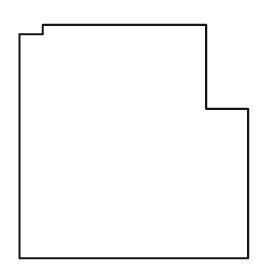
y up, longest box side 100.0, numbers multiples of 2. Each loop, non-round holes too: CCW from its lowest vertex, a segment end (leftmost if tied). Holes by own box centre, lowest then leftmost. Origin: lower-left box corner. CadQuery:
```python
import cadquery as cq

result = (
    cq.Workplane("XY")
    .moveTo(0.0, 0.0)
    .lineTo(98.0, 0.0)
    .lineTo(98.0, 64.0)
    .lineTo(80.0, 64.0)
    .lineTo(80.0, 100.0)
    .lineTo(10.0, 100.0)
    .lineTo(10.0, 96.0)
    .lineTo(0.0, 96.0)
    .close()
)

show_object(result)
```